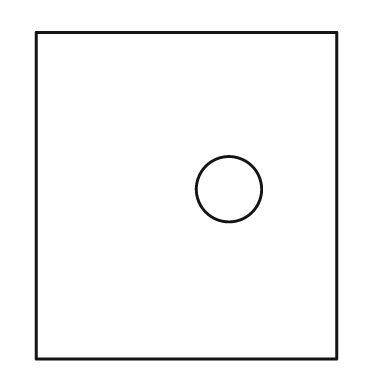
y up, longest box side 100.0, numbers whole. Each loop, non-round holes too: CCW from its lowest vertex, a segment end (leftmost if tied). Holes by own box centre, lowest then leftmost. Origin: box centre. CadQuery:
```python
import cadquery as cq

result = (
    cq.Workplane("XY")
    .moveTo(-46.0, -50.0)
    .lineTo(46.0, -50.0)
    .lineTo(46.0, 50.0)
    .lineTo(-46.0, 50.0)
    .close()
    .moveTo(13.0, 2.0)
    .circle(10.0)
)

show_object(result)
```